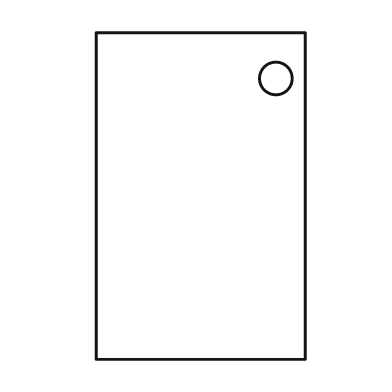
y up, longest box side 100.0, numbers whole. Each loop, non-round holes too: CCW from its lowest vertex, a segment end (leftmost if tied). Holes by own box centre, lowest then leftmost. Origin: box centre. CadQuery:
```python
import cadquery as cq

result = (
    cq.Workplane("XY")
    .moveTo(-32.0, -50.0)
    .lineTo(32.0, -50.0)
    .lineTo(32.0, 50.0)
    .lineTo(-32.0, 50.0)
    .close()
    .moveTo(23.0, 36.0)
    .circle(5.0)
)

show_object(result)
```